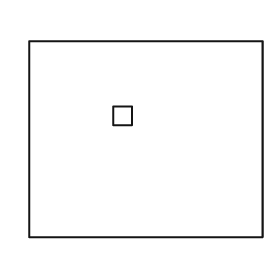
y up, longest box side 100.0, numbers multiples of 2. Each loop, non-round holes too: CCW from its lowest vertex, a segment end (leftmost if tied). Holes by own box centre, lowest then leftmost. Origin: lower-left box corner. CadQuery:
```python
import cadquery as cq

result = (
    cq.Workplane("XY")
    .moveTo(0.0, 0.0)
    .lineTo(100.0, 0.0)
    .lineTo(100.0, 84.0)
    .lineTo(0.0, 84.0)
    .close()
    .moveTo(36.0, 48.0)
    .lineTo(44.0, 48.0)
    .lineTo(44.0, 56.0)
    .lineTo(36.0, 56.0)
    .close()
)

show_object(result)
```